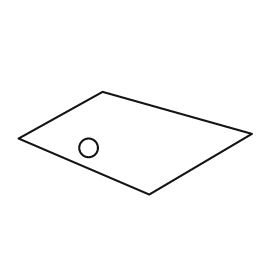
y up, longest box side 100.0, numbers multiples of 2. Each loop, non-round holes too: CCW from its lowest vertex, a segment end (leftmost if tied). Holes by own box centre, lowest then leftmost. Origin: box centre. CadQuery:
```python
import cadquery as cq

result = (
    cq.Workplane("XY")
    .moveTo(6.0, -22.0)
    .lineTo(50.0, 4.0)
    .lineTo(-14.0, 22.0)
    .lineTo(-50.0, 2.0)
    .close()
    .moveTo(-20.0, -2.0)
    .circle(4.0)
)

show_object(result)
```